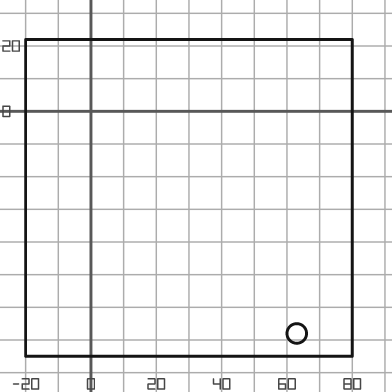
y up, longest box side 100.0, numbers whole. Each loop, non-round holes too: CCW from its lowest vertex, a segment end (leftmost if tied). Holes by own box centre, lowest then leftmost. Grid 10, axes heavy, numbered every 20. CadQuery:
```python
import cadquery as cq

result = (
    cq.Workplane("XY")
    .moveTo(-20.0, -75.0)
    .lineTo(80.0, -75.0)
    .lineTo(80.0, 22.0)
    .lineTo(-20.0, 22.0)
    .close()
    .moveTo(63.0, -68.0)
    .circle(3.0)
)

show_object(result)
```